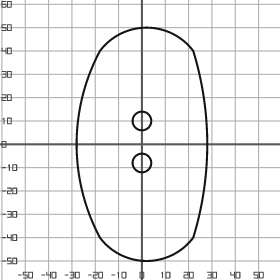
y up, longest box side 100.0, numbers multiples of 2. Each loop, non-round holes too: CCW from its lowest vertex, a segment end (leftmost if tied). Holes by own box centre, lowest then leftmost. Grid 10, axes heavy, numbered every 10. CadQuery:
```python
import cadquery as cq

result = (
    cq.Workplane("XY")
    .moveTo(-18.0, -40.0)
    .threePointArc((2.0, -50.0), (22.0, -40.0))
    .threePointArc((28.0, 0.0), (22.0, 40.0))
    .threePointArc((2.0, 50.0), (-18.0, 40.0))
    .threePointArc((-28.0, 0.0), (-18.0, -40.0))
    .close()
    .moveTo(0.0, -8.0)
    .circle(4.0)
    .moveTo(0.0, 10.0)
    .circle(4.0)
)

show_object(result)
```